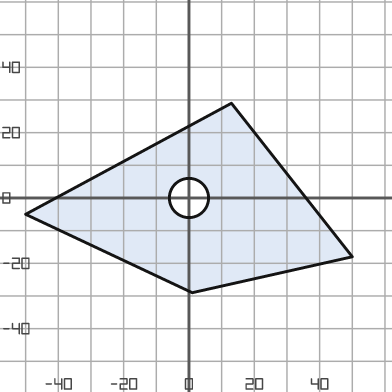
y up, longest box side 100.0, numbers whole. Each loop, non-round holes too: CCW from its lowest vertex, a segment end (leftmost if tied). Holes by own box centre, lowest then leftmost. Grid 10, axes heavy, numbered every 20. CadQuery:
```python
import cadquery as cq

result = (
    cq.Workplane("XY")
    .moveTo(1.0, -29.0)
    .lineTo(50.0, -18.0)
    .lineTo(13.0, 29.0)
    .lineTo(-50.0, -5.0)
    .close()
    .moveTo(0.0, 0.0)
    .circle(6.0)
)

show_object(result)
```